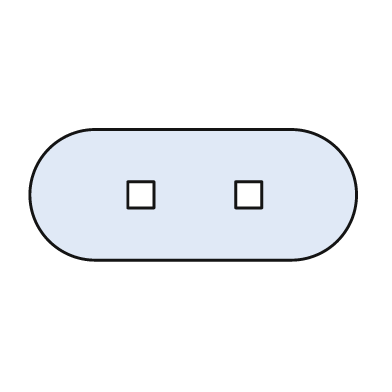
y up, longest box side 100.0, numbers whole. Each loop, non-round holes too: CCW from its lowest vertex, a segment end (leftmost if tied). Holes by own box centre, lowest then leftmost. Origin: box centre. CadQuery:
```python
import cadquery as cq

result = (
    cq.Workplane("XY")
    .moveTo(-30.0, -20.0)
    .lineTo(30.0, -20.0)
    .threePointArc((50.0, 0.0), (30.0, 20.0))
    .lineTo(-30.0, 20.0)
    .threePointArc((-50.0, 0.0), (-30.0, -20.0))
    .close()
    .moveTo(-20.0, -4.0)
    .lineTo(-12.0, -4.0)
    .lineTo(-12.0, 4.0)
    .lineTo(-20.0, 4.0)
    .close()
    .moveTo(13.0, -4.0)
    .lineTo(21.0, -4.0)
    .lineTo(21.0, 4.0)
    .lineTo(13.0, 4.0)
    .close()
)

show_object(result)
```